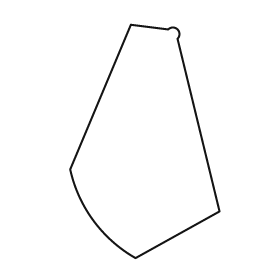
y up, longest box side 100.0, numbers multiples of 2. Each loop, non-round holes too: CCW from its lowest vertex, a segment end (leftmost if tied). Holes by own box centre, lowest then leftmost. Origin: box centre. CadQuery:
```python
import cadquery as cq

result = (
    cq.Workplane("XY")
    .moveTo(-4.0, -50.0)
    .lineTo(32.0, -30.0)
    .lineTo(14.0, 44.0)
    .threePointArc((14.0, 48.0), (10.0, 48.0))
    .lineTo(-6.0, 50.0)
    .lineTo(-32.0, -12.0)
    .threePointArc((-22.0, -34.0), (-4.0, -50.0))
    .close()
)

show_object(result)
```